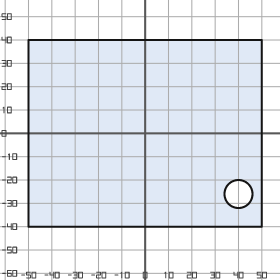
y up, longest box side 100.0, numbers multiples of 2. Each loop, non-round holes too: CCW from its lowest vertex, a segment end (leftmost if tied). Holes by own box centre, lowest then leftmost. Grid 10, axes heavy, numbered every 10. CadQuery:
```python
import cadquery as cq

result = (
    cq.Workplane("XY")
    .moveTo(-50.0, -40.0)
    .lineTo(50.0, -40.0)
    .lineTo(50.0, 40.0)
    .lineTo(-50.0, 40.0)
    .close()
    .moveTo(40.0, -26.0)
    .circle(6.0)
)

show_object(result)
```